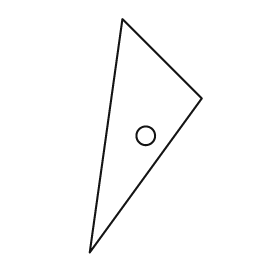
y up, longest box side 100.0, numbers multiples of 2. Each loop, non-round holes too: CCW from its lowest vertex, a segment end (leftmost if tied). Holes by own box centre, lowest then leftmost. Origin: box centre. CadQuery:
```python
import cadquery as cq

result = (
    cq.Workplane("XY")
    .moveTo(-24.0, -50.0)
    .lineTo(24.0, 16.0)
    .lineTo(-10.0, 50.0)
    .close()
    .moveTo(0.0, 0.0)
    .circle(4.0)
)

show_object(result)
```